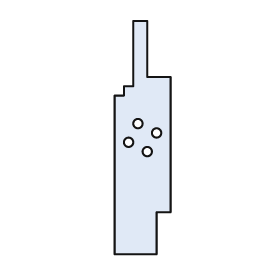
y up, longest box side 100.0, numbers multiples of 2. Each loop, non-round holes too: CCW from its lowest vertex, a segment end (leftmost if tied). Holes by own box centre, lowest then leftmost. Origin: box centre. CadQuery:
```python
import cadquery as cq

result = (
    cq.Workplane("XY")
    .moveTo(-12.0, -50.0)
    .lineTo(6.0, -50.0)
    .lineTo(6.0, -32.0)
    .lineTo(12.0, -32.0)
    .lineTo(12.0, 26.0)
    .lineTo(2.0, 26.0)
    .lineTo(2.0, 50.0)
    .lineTo(-4.0, 50.0)
    .lineTo(-4.0, 22.0)
    .lineTo(-8.0, 22.0)
    .lineTo(-8.0, 18.0)
    .lineTo(-12.0, 18.0)
    .close()
    .moveTo(2.0, -6.0)
    .circle(2.0)
    .moveTo(-6.0, -2.0)
    .circle(2.0)
    .moveTo(6.0, 2.0)
    .circle(2.0)
    .moveTo(-2.0, 6.0)
    .circle(2.0)
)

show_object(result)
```